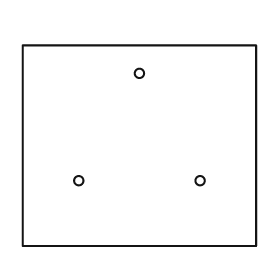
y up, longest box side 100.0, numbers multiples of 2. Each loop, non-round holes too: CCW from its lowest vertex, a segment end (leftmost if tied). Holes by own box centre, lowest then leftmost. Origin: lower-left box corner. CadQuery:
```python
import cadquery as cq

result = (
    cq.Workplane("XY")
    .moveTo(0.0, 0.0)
    .lineTo(100.0, 0.0)
    .lineTo(100.0, 86.0)
    .lineTo(0.0, 86.0)
    .close()
    .moveTo(24.0, 28.0)
    .circle(2.0)
    .moveTo(76.0, 28.0)
    .circle(2.0)
    .moveTo(50.0, 74.0)
    .circle(2.0)
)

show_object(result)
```